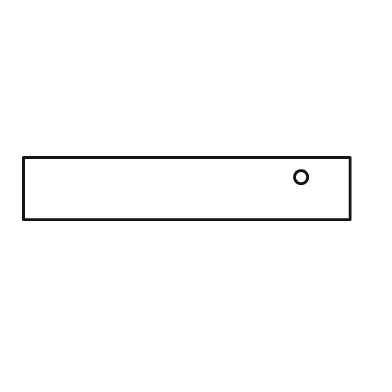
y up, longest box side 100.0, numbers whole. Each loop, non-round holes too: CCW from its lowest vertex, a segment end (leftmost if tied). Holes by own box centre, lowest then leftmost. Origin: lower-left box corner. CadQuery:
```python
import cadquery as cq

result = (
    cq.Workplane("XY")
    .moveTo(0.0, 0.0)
    .lineTo(100.0, 0.0)
    .lineTo(100.0, 19.0)
    .lineTo(0.0, 19.0)
    .close()
    .moveTo(85.0, 13.0)
    .circle(2.0)
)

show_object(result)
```